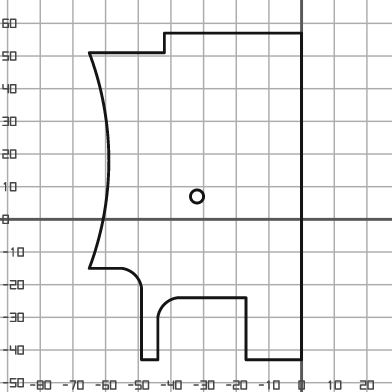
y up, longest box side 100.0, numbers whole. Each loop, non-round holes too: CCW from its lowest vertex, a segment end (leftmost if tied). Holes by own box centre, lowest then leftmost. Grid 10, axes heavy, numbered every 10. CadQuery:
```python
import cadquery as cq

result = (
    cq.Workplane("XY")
    .moveTo(-49.0, -43.0)
    .lineTo(-44.0, -43.0)
    .lineTo(-44.0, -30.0)
    .threePointArc((-42.0, -26.0), (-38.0, -24.0))
    .lineTo(-17.0, -24.0)
    .lineTo(-17.0, -43.0)
    .lineTo(0.0, -43.0)
    .lineTo(0.0, 57.0)
    .lineTo(-42.0, 57.0)
    .lineTo(-42.0, 51.0)
    .lineTo(-65.0, 51.0)
    .threePointArc((-59.0, 18.0), (-65.0, -15.0))
    .lineTo(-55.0, -15.0)
    .threePointArc((-51.0, -17.0), (-49.0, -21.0))
    .close()
    .moveTo(-32.0, 7.0)
    .circle(2.0)
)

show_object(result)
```